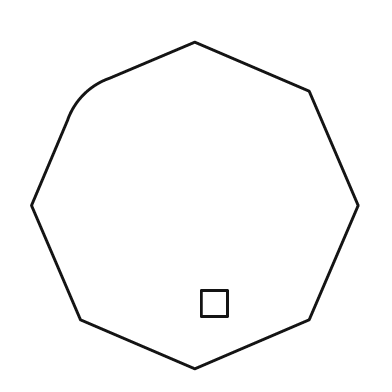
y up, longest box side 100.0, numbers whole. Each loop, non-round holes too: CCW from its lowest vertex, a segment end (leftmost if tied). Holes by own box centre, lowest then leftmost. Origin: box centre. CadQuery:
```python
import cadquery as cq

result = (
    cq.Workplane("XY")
    .moveTo(0.0, -50.0)
    .lineTo(35.0, -35.0)
    .lineTo(50.0, 0.0)
    .lineTo(35.0, 35.0)
    .lineTo(0.0, 50.0)
    .lineTo(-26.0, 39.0)
    .threePointArc((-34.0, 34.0), (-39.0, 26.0))
    .lineTo(-50.0, 0.0)
    .lineTo(-35.0, -35.0)
    .close()
    .moveTo(2.0, -34.0)
    .lineTo(10.0, -34.0)
    .lineTo(10.0, -26.0)
    .lineTo(2.0, -26.0)
    .close()
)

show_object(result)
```